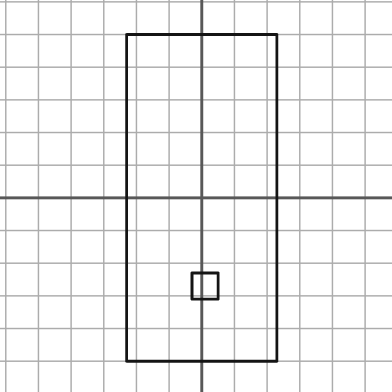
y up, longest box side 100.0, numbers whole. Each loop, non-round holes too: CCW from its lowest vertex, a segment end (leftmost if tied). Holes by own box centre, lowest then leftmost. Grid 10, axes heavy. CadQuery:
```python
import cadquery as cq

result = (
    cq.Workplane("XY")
    .moveTo(-23.0, -50.0)
    .lineTo(23.0, -50.0)
    .lineTo(23.0, 50.0)
    .lineTo(-23.0, 50.0)
    .close()
    .moveTo(-3.0, -31.0)
    .lineTo(5.0, -31.0)
    .lineTo(5.0, -23.0)
    .lineTo(-3.0, -23.0)
    .close()
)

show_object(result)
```